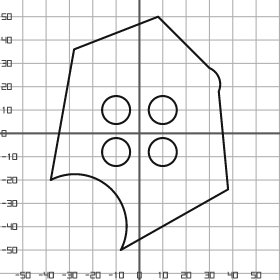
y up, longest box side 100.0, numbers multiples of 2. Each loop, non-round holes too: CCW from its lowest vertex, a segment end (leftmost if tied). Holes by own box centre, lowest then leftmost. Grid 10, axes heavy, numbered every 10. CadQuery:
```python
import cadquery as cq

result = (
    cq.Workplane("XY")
    .moveTo(-8.0, -50.0)
    .lineTo(38.0, -24.0)
    .lineTo(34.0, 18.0)
    .threePointArc((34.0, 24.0), (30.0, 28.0))
    .lineTo(8.0, 50.0)
    .lineTo(-28.0, 36.0)
    .lineTo(-38.0, -20.0)
    .threePointArc((-12.0, -24.0), (-8.0, -50.0))
    .close()
    .moveTo(-10.0, -8.0)
    .circle(6.0)
    .moveTo(10.0, -8.0)
    .circle(6.0)
    .moveTo(-10.0, 10.0)
    .circle(6.0)
    .moveTo(10.0, 10.0)
    .circle(6.0)
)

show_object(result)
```